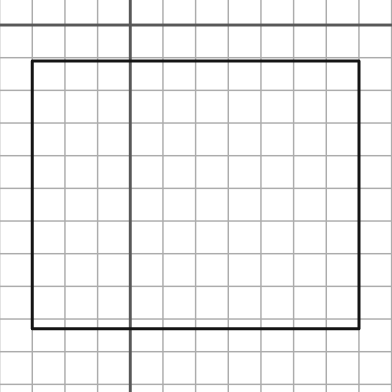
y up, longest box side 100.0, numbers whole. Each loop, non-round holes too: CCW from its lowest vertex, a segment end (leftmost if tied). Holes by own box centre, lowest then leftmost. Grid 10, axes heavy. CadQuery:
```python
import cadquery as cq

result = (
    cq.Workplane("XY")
    .moveTo(-30.0, -93.0)
    .lineTo(70.0, -93.0)
    .lineTo(70.0, -11.0)
    .lineTo(-30.0, -11.0)
    .close()
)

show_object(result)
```